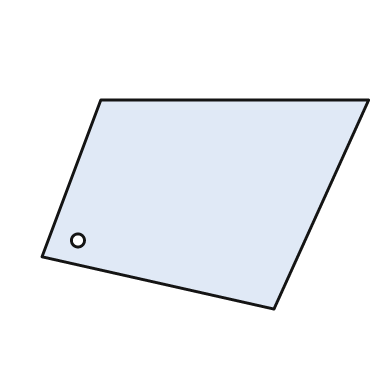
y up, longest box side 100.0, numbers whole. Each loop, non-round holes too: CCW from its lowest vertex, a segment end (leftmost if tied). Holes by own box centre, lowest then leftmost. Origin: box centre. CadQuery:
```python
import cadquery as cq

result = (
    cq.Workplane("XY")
    .moveTo(21.0, -32.0)
    .lineTo(50.0, 32.0)
    .lineTo(-32.0, 32.0)
    .lineTo(-50.0, -16.0)
    .close()
    .moveTo(-39.0, -11.0)
    .circle(2.0)
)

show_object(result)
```